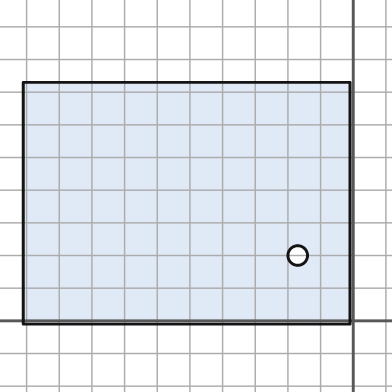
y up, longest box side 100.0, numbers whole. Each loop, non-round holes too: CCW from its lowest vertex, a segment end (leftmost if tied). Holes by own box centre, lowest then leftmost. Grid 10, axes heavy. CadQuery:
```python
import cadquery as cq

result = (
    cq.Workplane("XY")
    .moveTo(-101.0, -1.0)
    .lineTo(-1.0, -1.0)
    .lineTo(-1.0, 73.0)
    .lineTo(-101.0, 73.0)
    .close()
    .moveTo(-17.0, 20.0)
    .circle(3.0)
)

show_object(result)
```